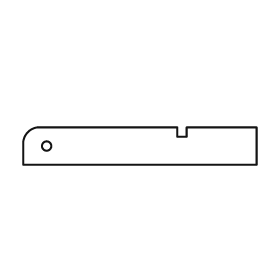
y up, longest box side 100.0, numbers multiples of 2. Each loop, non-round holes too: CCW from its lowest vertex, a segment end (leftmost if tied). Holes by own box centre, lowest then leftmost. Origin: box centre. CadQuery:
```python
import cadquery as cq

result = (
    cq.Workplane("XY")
    .moveTo(-50.0, -8.0)
    .lineTo(50.0, -8.0)
    .lineTo(50.0, 8.0)
    .lineTo(20.0, 8.0)
    .lineTo(20.0, 4.0)
    .lineTo(16.0, 4.0)
    .lineTo(16.0, 8.0)
    .lineTo(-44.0, 8.0)
    .threePointArc((-48.0, 6.0), (-50.0, 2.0))
    .close()
    .moveTo(-40.0, 0.0)
    .circle(2.0)
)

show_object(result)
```